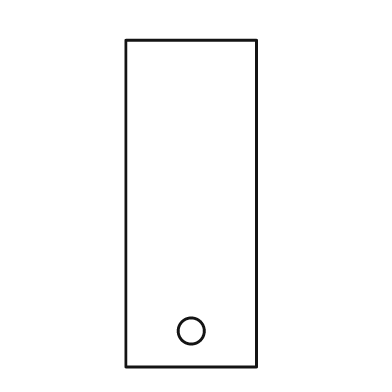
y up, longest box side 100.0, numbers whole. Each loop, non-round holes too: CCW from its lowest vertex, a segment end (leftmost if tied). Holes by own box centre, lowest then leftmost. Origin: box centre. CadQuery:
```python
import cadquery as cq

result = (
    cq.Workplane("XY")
    .moveTo(-20.0, -50.0)
    .lineTo(20.0, -50.0)
    .lineTo(20.0, 50.0)
    .lineTo(-20.0, 50.0)
    .close()
    .moveTo(0.0, -39.0)
    .circle(4.0)
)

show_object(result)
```